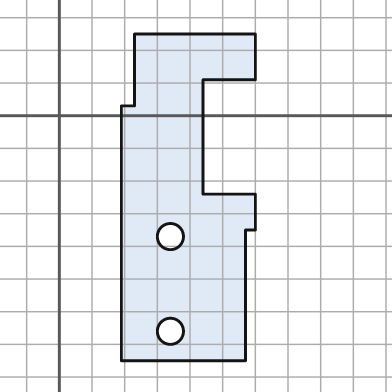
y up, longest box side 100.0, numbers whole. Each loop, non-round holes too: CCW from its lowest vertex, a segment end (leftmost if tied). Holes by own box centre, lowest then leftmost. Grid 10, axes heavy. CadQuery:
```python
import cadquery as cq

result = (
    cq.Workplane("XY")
    .moveTo(19.0, -75.0)
    .lineTo(57.0, -75.0)
    .lineTo(57.0, -35.0)
    .lineTo(60.0, -35.0)
    .lineTo(60.0, -24.0)
    .lineTo(44.0, -24.0)
    .lineTo(44.0, 11.0)
    .lineTo(60.0, 11.0)
    .lineTo(60.0, 25.0)
    .lineTo(23.0, 25.0)
    .lineTo(23.0, 3.0)
    .lineTo(19.0, 3.0)
    .close()
    .moveTo(34.0, -66.0)
    .circle(4.0)
    .moveTo(34.0, -37.0)
    .circle(4.0)
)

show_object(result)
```